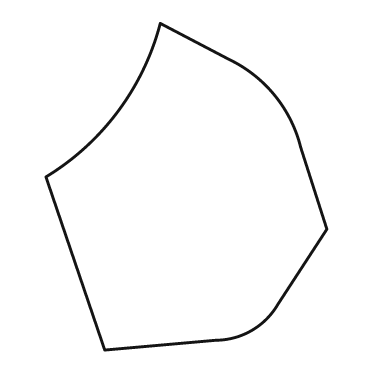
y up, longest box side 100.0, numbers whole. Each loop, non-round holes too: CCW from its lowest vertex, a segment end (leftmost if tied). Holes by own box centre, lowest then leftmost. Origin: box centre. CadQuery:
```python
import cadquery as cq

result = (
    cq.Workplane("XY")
    .moveTo(-25.0, -50.0)
    .lineTo(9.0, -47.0)
    .threePointArc((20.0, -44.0), (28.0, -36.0))
    .lineTo(43.0, -13.0)
    .lineTo(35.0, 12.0)
    .threePointArc((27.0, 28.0), (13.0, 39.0))
    .lineTo(-8.0, 50.0)
    .threePointArc((-21.0, 23.0), (-43.0, 3.0))
    .close()
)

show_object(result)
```